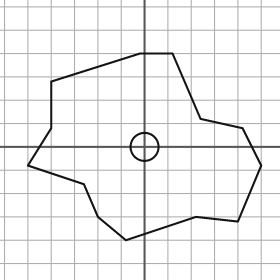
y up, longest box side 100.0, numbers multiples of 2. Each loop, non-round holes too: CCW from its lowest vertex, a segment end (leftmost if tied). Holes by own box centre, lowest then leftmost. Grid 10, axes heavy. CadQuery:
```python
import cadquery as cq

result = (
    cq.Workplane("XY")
    .moveTo(-8.0, -40.0)
    .lineTo(22.0, -30.0)
    .lineTo(40.0, -32.0)
    .lineTo(50.0, -8.0)
    .lineTo(42.0, 8.0)
    .lineTo(24.0, 12.0)
    .lineTo(12.0, 40.0)
    .lineTo(-2.0, 40.0)
    .lineTo(-40.0, 28.0)
    .lineTo(-40.0, 8.0)
    .lineTo(-50.0, -8.0)
    .lineTo(-26.0, -16.0)
    .lineTo(-20.0, -30.0)
    .close()
    .moveTo(0.0, 0.0)
    .circle(6.0)
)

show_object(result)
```